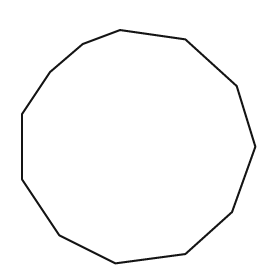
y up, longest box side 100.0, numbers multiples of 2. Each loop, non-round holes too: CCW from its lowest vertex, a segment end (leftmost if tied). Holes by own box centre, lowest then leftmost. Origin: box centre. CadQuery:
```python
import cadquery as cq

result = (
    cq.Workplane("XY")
    .moveTo(-10.0, -50.0)
    .lineTo(20.0, -46.0)
    .lineTo(40.0, -28.0)
    .lineTo(50.0, 0.0)
    .lineTo(42.0, 26.0)
    .lineTo(20.0, 46.0)
    .lineTo(-8.0, 50.0)
    .lineTo(-24.0, 44.0)
    .lineTo(-38.0, 32.0)
    .lineTo(-50.0, 14.0)
    .lineTo(-50.0, -14.0)
    .lineTo(-34.0, -38.0)
    .close()
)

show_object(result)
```